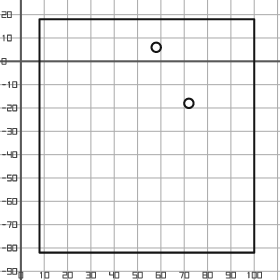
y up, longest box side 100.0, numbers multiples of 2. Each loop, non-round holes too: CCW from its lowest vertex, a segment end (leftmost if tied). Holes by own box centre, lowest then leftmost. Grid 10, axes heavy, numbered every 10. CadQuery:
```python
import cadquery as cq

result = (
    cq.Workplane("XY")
    .moveTo(8.0, -82.0)
    .lineTo(100.0, -82.0)
    .lineTo(100.0, 18.0)
    .lineTo(8.0, 18.0)
    .close()
    .moveTo(72.0, -18.0)
    .circle(2.0)
    .moveTo(58.0, 6.0)
    .circle(2.0)
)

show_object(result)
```